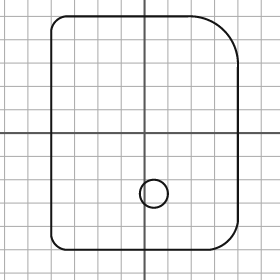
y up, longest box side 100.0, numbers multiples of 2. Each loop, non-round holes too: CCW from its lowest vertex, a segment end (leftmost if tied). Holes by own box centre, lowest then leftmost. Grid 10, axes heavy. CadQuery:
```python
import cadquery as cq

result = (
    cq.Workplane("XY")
    .moveTo(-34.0, -50.0)
    .lineTo(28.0, -50.0)
    .threePointArc((36.0, -46.0), (40.0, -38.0))
    .lineTo(40.0, 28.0)
    .threePointArc((34.0, 44.0), (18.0, 50.0))
    .lineTo(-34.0, 50.0)
    .threePointArc((-38.0, 48.0), (-40.0, 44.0))
    .lineTo(-40.0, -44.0)
    .threePointArc((-38.0, -48.0), (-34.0, -50.0))
    .close()
    .moveTo(4.0, -26.0)
    .circle(6.0)
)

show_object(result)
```